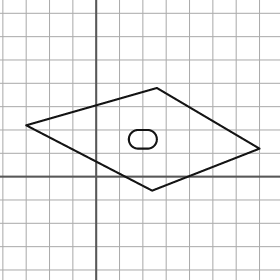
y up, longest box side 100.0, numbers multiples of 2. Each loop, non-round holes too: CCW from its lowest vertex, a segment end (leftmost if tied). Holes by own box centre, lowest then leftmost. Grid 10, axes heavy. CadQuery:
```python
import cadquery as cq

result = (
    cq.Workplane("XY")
    .moveTo(24.0, -6.0)
    .lineTo(70.0, 12.0)
    .lineTo(26.0, 38.0)
    .lineTo(-30.0, 22.0)
    .close()
    .moveTo(18.0, 12.0)
    .lineTo(22.0, 12.0)
    .threePointArc((26.0, 16.0), (22.0, 20.0))
    .lineTo(18.0, 20.0)
    .threePointArc((14.0, 16.0), (18.0, 12.0))
    .close()
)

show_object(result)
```